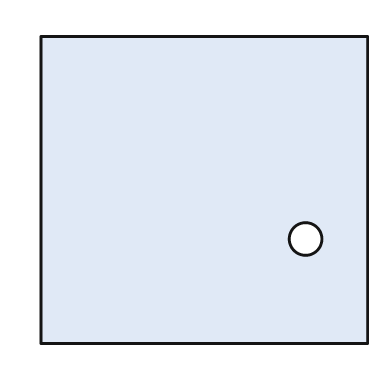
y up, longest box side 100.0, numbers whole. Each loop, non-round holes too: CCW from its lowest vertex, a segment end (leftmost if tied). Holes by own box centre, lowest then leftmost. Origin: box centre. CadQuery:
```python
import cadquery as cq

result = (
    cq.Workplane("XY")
    .moveTo(-50.0, -47.0)
    .lineTo(50.0, -47.0)
    .lineTo(50.0, 47.0)
    .lineTo(-50.0, 47.0)
    .close()
    .moveTo(31.0, -15.0)
    .circle(5.0)
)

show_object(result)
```